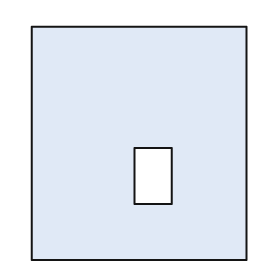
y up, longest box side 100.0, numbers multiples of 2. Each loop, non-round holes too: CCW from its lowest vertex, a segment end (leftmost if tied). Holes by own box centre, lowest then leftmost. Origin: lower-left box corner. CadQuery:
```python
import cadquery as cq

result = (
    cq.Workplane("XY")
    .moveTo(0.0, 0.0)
    .lineTo(92.0, 0.0)
    .lineTo(92.0, 100.0)
    .lineTo(0.0, 100.0)
    .close()
    .moveTo(44.0, 24.0)
    .lineTo(60.0, 24.0)
    .lineTo(60.0, 48.0)
    .lineTo(44.0, 48.0)
    .close()
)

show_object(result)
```